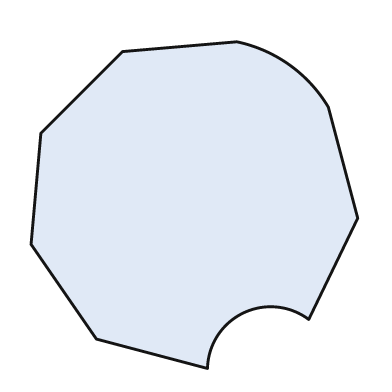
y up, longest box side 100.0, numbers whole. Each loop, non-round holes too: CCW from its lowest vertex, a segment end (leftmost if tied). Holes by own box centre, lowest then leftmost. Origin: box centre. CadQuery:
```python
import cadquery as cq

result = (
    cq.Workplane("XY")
    .moveTo(4.0, -50.0)
    .threePointArc((15.0, -33.0), (35.0, -35.0))
    .lineTo(50.0, -4.0)
    .lineTo(41.0, 30.0)
    .threePointArc((29.0, 43.0), (13.0, 50.0))
    .lineTo(-22.0, 47.0)
    .lineTo(-47.0, 22.0)
    .lineTo(-50.0, -12.0)
    .lineTo(-30.0, -41.0)
    .close()
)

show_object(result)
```